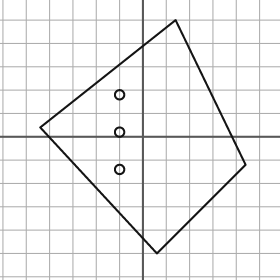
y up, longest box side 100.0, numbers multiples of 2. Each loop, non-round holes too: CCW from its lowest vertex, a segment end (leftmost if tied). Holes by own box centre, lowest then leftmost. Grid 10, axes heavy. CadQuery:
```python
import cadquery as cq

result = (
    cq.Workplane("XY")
    .moveTo(6.0, -50.0)
    .lineTo(44.0, -12.0)
    .lineTo(14.0, 50.0)
    .lineTo(-44.0, 4.0)
    .close()
    .moveTo(-10.0, -14.0)
    .circle(2.0)
    .moveTo(-10.0, 2.0)
    .circle(2.0)
    .moveTo(-10.0, 18.0)
    .circle(2.0)
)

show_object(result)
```